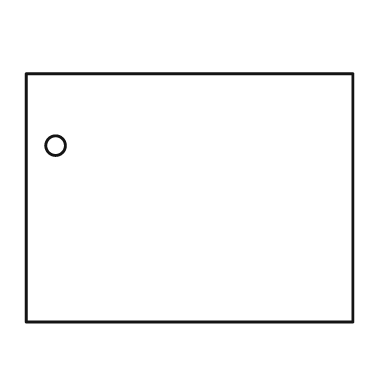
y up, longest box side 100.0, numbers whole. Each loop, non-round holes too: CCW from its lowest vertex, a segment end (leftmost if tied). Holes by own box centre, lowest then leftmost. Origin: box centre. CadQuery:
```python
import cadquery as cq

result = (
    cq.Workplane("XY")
    .moveTo(-50.0, -38.0)
    .lineTo(50.0, -38.0)
    .lineTo(50.0, 38.0)
    .lineTo(-50.0, 38.0)
    .close()
    .moveTo(-41.0, 16.0)
    .circle(3.0)
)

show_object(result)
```